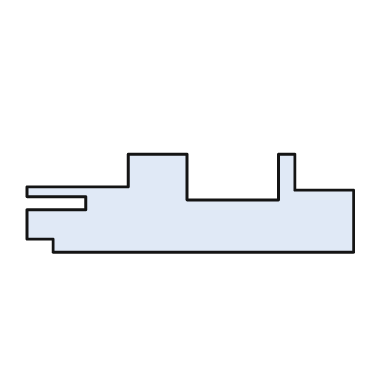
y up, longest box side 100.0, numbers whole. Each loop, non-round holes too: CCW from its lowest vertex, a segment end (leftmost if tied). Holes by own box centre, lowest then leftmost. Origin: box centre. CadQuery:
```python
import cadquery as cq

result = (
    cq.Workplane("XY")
    .moveTo(-42.0, -15.0)
    .lineTo(50.0, -15.0)
    .lineTo(50.0, 4.0)
    .lineTo(32.0, 4.0)
    .lineTo(32.0, 15.0)
    .lineTo(27.0, 15.0)
    .lineTo(27.0, 1.0)
    .lineTo(-1.0, 1.0)
    .lineTo(-1.0, 15.0)
    .lineTo(-19.0, 15.0)
    .lineTo(-19.0, 5.0)
    .lineTo(-50.0, 5.0)
    .lineTo(-50.0, 2.0)
    .lineTo(-32.0, 2.0)
    .lineTo(-32.0, -2.0)
    .lineTo(-50.0, -2.0)
    .lineTo(-50.0, -11.0)
    .lineTo(-42.0, -11.0)
    .close()
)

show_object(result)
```